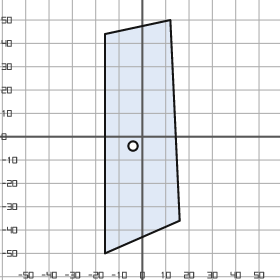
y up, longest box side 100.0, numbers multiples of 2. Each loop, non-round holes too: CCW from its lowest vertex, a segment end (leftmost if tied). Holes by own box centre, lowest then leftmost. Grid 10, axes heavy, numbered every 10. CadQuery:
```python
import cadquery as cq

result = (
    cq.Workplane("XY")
    .moveTo(-16.0, -50.0)
    .lineTo(16.0, -36.0)
    .lineTo(12.0, 50.0)
    .lineTo(-16.0, 44.0)
    .close()
    .moveTo(-4.0, -4.0)
    .circle(2.0)
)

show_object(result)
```